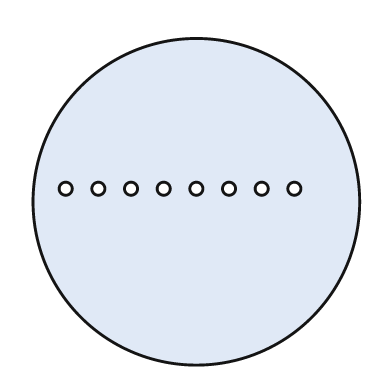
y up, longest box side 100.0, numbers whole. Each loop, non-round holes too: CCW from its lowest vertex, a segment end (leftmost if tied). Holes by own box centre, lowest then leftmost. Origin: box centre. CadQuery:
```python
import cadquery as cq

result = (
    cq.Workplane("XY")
    .moveTo(0.0, 0.0)
    .circle(50.0)
    .moveTo(-40.0, 4.0)
    .circle(2.0)
    .moveTo(-30.0, 4.0)
    .circle(2.0)
    .moveTo(-20.0, 4.0)
    .circle(2.0)
    .moveTo(-10.0, 4.0)
    .circle(2.0)
    .moveTo(0.0, 4.0)
    .circle(2.0)
    .moveTo(10.0, 4.0)
    .circle(2.0)
    .moveTo(20.0, 4.0)
    .circle(2.0)
    .moveTo(30.0, 4.0)
    .circle(2.0)
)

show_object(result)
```